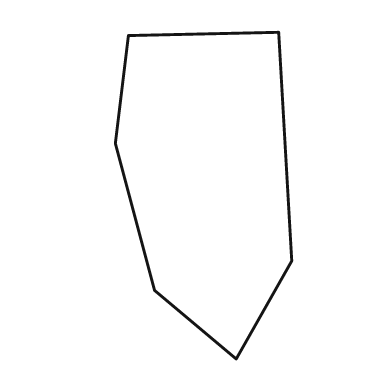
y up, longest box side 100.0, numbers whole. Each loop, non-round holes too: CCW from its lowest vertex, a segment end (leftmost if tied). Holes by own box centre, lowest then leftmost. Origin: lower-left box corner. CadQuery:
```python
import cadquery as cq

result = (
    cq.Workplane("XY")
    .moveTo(37.0, 0.0)
    .lineTo(54.0, 30.0)
    .lineTo(50.0, 100.0)
    .lineTo(4.0, 99.0)
    .lineTo(0.0, 66.0)
    .lineTo(12.0, 21.0)
    .close()
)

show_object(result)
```